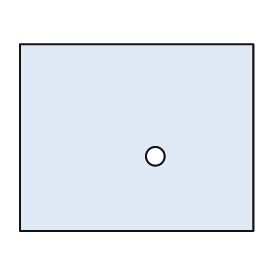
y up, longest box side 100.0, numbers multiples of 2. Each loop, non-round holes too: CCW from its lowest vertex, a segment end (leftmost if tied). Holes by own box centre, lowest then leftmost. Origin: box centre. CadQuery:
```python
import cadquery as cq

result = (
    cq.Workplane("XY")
    .moveTo(-50.0, -40.0)
    .lineTo(50.0, -40.0)
    .lineTo(50.0, 40.0)
    .lineTo(-50.0, 40.0)
    .close()
    .moveTo(8.0, -8.0)
    .circle(4.0)
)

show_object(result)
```